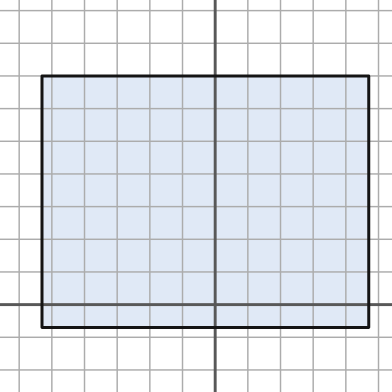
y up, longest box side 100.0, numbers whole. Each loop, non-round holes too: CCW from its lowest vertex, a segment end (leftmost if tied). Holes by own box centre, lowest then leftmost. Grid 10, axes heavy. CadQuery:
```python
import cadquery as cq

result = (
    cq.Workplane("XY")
    .moveTo(-53.0, -7.0)
    .lineTo(47.0, -7.0)
    .lineTo(47.0, 70.0)
    .lineTo(-53.0, 70.0)
    .close()
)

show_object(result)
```